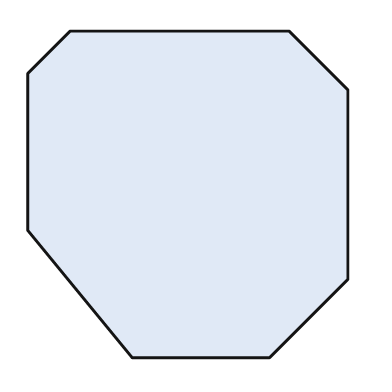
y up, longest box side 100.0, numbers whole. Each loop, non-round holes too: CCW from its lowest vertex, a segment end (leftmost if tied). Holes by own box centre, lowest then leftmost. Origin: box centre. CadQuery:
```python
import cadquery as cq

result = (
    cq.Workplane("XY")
    .moveTo(-17.0, -50.0)
    .lineTo(25.0, -50.0)
    .lineTo(49.0, -26.0)
    .lineTo(49.0, 32.0)
    .lineTo(31.0, 50.0)
    .lineTo(-36.0, 50.0)
    .lineTo(-49.0, 37.0)
    .lineTo(-49.0, -11.0)
    .close()
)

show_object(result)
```